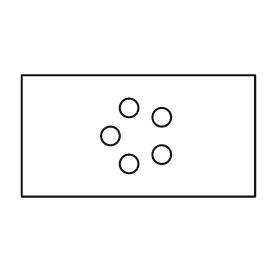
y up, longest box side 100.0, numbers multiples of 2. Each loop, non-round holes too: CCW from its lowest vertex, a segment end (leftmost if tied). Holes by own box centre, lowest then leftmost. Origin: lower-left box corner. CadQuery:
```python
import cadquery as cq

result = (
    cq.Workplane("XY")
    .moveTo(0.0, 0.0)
    .lineTo(100.0, 0.0)
    .lineTo(100.0, 52.0)
    .lineTo(0.0, 52.0)
    .close()
    .moveTo(46.0, 14.0)
    .circle(4.0)
    .moveTo(60.0, 18.0)
    .circle(4.0)
    .moveTo(38.0, 26.0)
    .circle(4.0)
    .moveTo(60.0, 34.0)
    .circle(4.0)
    .moveTo(46.0, 38.0)
    .circle(4.0)
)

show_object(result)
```